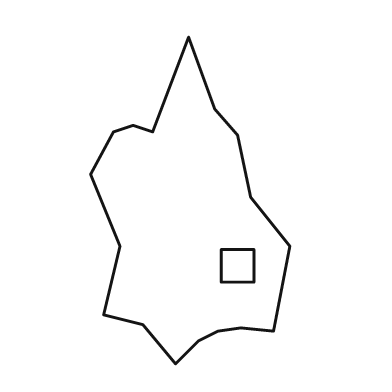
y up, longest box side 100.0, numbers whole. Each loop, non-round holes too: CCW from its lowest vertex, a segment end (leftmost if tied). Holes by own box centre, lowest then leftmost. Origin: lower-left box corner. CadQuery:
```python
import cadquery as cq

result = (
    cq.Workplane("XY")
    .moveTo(26.0, 0.0)
    .lineTo(33.0, 7.0)
    .lineTo(39.0, 10.0)
    .lineTo(46.0, 11.0)
    .lineTo(56.0, 10.0)
    .lineTo(61.0, 36.0)
    .lineTo(49.0, 51.0)
    .lineTo(45.0, 70.0)
    .lineTo(38.0, 78.0)
    .lineTo(30.0, 100.0)
    .lineTo(19.0, 71.0)
    .lineTo(13.0, 73.0)
    .lineTo(7.0, 71.0)
    .lineTo(0.0, 58.0)
    .lineTo(9.0, 36.0)
    .lineTo(4.0, 15.0)
    .lineTo(16.0, 12.0)
    .close()
    .moveTo(40.0, 25.0)
    .lineTo(50.0, 25.0)
    .lineTo(50.0, 35.0)
    .lineTo(40.0, 35.0)
    .close()
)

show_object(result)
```